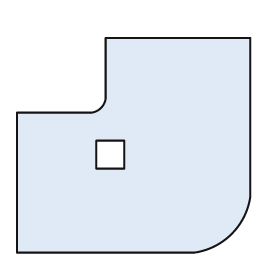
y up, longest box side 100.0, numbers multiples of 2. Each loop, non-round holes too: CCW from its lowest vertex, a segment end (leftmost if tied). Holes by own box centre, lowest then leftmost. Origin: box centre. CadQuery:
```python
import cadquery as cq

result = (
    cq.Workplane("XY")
    .moveTo(-50.0, -46.0)
    .lineTo(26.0, -46.0)
    .threePointArc((42.0, -38.0), (50.0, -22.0))
    .lineTo(50.0, 46.0)
    .lineTo(-12.0, 46.0)
    .lineTo(-12.0, 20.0)
    .threePointArc((-14.0, 16.0), (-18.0, 14.0))
    .lineTo(-50.0, 14.0)
    .close()
    .moveTo(-16.0, -10.0)
    .lineTo(-4.0, -10.0)
    .lineTo(-4.0, 2.0)
    .lineTo(-16.0, 2.0)
    .close()
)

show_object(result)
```